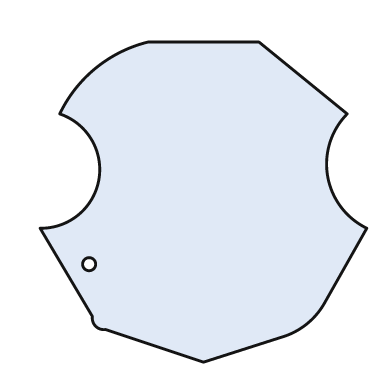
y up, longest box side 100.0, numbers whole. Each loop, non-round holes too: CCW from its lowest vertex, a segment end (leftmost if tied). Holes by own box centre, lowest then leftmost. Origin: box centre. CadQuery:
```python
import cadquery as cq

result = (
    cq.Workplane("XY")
    .moveTo(0.0, -49.0)
    .lineTo(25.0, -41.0)
    .threePointArc((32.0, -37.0), (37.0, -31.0))
    .lineTo(50.0, -8.0)
    .threePointArc((38.0, 8.0), (44.0, 27.0))
    .lineTo(17.0, 49.0)
    .lineTo(-17.0, 49.0)
    .threePointArc((-33.0, 41.0), (-44.0, 27.0))
    .threePointArc((-32.0, 7.0), (-50.0, -8.0))
    .lineTo(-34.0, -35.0)
    .threePointArc((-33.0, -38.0), (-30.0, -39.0))
    .close()
    .moveTo(-35.0, -19.0)
    .circle(2.0)
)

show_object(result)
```